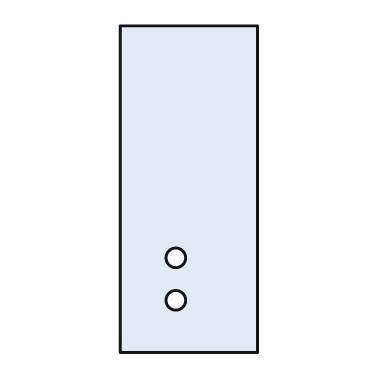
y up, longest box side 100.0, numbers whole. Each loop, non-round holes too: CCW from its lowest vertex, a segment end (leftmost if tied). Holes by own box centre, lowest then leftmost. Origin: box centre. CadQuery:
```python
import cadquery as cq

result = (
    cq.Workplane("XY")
    .moveTo(-21.0, -50.0)
    .lineTo(21.0, -50.0)
    .lineTo(21.0, 50.0)
    .lineTo(-21.0, 50.0)
    .close()
    .moveTo(-4.0, -34.0)
    .circle(3.0)
    .moveTo(-4.0, -21.0)
    .circle(3.0)
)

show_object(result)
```